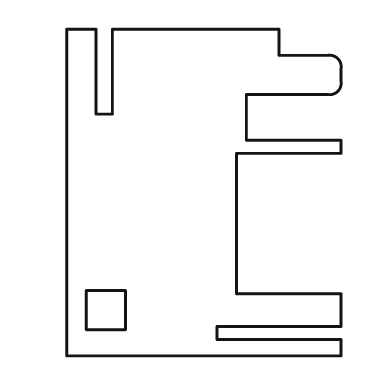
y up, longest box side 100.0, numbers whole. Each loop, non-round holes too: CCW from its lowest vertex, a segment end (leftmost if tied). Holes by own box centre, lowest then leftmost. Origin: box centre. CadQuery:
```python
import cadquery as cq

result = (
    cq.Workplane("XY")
    .moveTo(-42.0, -50.0)
    .lineTo(42.0, -50.0)
    .lineTo(42.0, -45.0)
    .lineTo(4.0, -45.0)
    .lineTo(4.0, -41.0)
    .lineTo(42.0, -41.0)
    .lineTo(42.0, -31.0)
    .lineTo(10.0, -31.0)
    .lineTo(10.0, 12.0)
    .lineTo(42.0, 12.0)
    .lineTo(42.0, 16.0)
    .lineTo(13.0, 16.0)
    .lineTo(13.0, 30.0)
    .lineTo(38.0, 30.0)
    .threePointArc((41.0, 31.0), (42.0, 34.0))
    .lineTo(42.0, 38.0)
    .threePointArc((41.0, 41.0), (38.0, 42.0))
    .lineTo(23.0, 42.0)
    .lineTo(23.0, 50.0)
    .lineTo(-28.0, 50.0)
    .lineTo(-28.0, 24.0)
    .lineTo(-33.0, 24.0)
    .lineTo(-33.0, 50.0)
    .lineTo(-42.0, 50.0)
    .close()
    .moveTo(-36.0, -42.0)
    .lineTo(-24.0, -42.0)
    .lineTo(-24.0, -30.0)
    .lineTo(-36.0, -30.0)
    .close()
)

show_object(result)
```